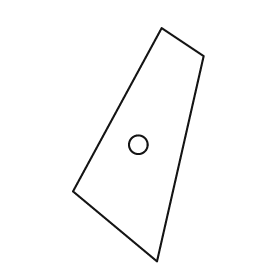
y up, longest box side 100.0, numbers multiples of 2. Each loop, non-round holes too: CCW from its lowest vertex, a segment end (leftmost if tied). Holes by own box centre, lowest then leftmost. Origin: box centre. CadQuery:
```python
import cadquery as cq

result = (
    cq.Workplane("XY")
    .moveTo(8.0, -50.0)
    .lineTo(28.0, 38.0)
    .lineTo(10.0, 50.0)
    .lineTo(-28.0, -20.0)
    .close()
    .moveTo(0.0, 0.0)
    .circle(4.0)
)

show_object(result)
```